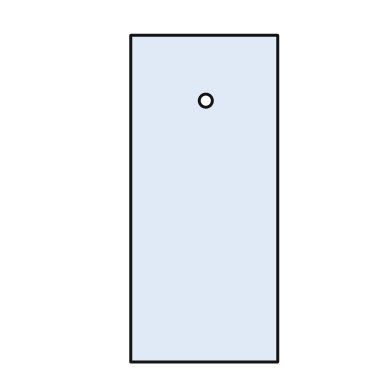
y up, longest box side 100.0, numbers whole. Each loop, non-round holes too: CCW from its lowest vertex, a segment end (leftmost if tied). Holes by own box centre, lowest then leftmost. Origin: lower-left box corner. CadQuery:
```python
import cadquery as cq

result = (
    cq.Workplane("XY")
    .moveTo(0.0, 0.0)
    .lineTo(45.0, 0.0)
    .lineTo(45.0, 100.0)
    .lineTo(0.0, 100.0)
    .close()
    .moveTo(23.0, 80.0)
    .circle(2.0)
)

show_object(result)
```